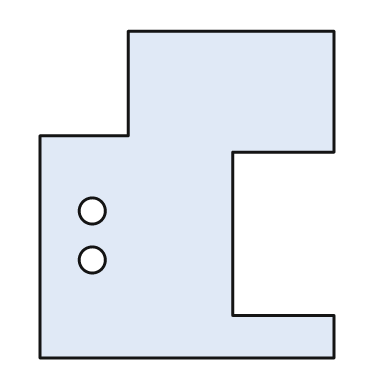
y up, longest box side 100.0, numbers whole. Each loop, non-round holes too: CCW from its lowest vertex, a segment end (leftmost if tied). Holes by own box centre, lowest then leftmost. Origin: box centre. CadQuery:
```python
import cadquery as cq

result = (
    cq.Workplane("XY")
    .moveTo(-45.0, -50.0)
    .lineTo(45.0, -50.0)
    .lineTo(45.0, -37.0)
    .lineTo(14.0, -37.0)
    .lineTo(14.0, 13.0)
    .lineTo(45.0, 13.0)
    .lineTo(45.0, 50.0)
    .lineTo(-18.0, 50.0)
    .lineTo(-18.0, 18.0)
    .lineTo(-45.0, 18.0)
    .close()
    .moveTo(-29.0, -20.0)
    .circle(4.0)
    .moveTo(-29.0, -5.0)
    .circle(4.0)
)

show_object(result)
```